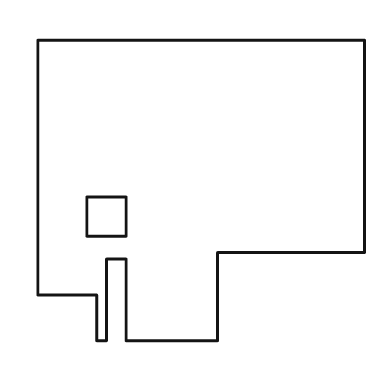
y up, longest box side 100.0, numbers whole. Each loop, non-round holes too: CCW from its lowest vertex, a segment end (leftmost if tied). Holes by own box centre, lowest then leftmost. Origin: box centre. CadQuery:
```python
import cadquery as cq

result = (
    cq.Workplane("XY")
    .moveTo(-32.0, -46.0)
    .lineTo(-29.0, -46.0)
    .lineTo(-29.0, -21.0)
    .lineTo(-23.0, -21.0)
    .lineTo(-23.0, -46.0)
    .lineTo(5.0, -46.0)
    .lineTo(5.0, -19.0)
    .lineTo(50.0, -19.0)
    .lineTo(50.0, 46.0)
    .lineTo(-50.0, 46.0)
    .lineTo(-50.0, -32.0)
    .lineTo(-32.0, -32.0)
    .close()
    .moveTo(-35.0, -14.0)
    .lineTo(-23.0, -14.0)
    .lineTo(-23.0, -2.0)
    .lineTo(-35.0, -2.0)
    .close()
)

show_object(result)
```